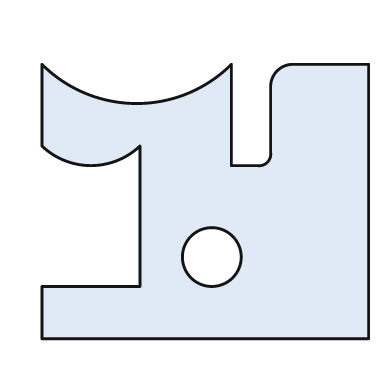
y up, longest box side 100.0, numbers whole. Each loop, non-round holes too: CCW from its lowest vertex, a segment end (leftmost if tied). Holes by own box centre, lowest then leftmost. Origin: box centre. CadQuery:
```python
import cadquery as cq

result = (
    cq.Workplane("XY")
    .moveTo(-50.0, -42.0)
    .lineTo(50.0, -42.0)
    .lineTo(50.0, 42.0)
    .lineTo(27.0, 42.0)
    .threePointArc((22.0, 40.0), (20.0, 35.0))
    .lineTo(20.0, 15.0)
    .threePointArc((19.0, 12.0), (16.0, 11.0))
    .lineTo(8.0, 11.0)
    .lineTo(8.0, 42.0)
    .threePointArc((-21.0, 30.0), (-50.0, 42.0))
    .lineTo(-50.0, 17.0)
    .threePointArc((-35.0, 11.0), (-20.0, 17.0))
    .lineTo(-20.0, -26.0)
    .lineTo(-50.0, -26.0)
    .close()
    .moveTo(2.0, -17.0)
    .circle(9.0)
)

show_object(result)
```